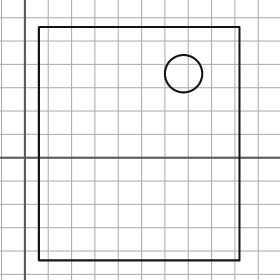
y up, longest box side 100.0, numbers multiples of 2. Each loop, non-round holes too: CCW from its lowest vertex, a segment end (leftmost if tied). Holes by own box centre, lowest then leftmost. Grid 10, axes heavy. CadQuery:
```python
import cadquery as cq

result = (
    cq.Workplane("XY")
    .moveTo(6.0, -44.0)
    .lineTo(92.0, -44.0)
    .lineTo(92.0, 56.0)
    .lineTo(6.0, 56.0)
    .close()
    .moveTo(68.0, 36.0)
    .circle(8.0)
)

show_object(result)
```